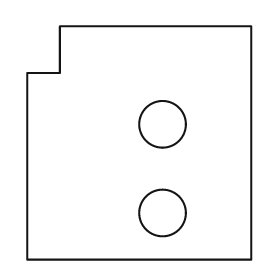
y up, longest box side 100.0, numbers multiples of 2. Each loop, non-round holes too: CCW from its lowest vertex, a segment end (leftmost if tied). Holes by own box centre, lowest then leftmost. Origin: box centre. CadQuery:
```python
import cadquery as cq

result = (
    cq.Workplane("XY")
    .moveTo(-48.0, -50.0)
    .lineTo(48.0, -50.0)
    .lineTo(48.0, 50.0)
    .lineTo(-34.0, 50.0)
    .lineTo(-34.0, 30.0)
    .lineTo(-48.0, 30.0)
    .close()
    .moveTo(10.0, -30.0)
    .circle(10.0)
    .moveTo(10.0, 8.0)
    .circle(10.0)
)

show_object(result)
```